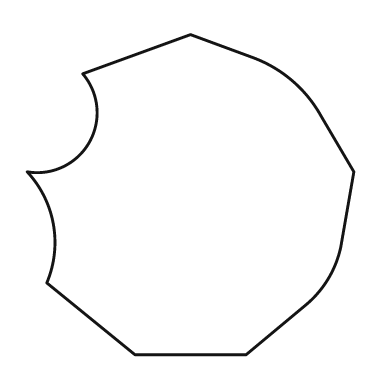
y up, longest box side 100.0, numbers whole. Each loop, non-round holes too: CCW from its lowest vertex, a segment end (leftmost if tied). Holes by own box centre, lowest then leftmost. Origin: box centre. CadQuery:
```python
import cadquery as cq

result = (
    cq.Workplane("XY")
    .moveTo(-17.0, -49.0)
    .lineTo(17.0, -49.0)
    .lineTo(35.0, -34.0)
    .threePointArc((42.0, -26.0), (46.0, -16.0))
    .lineTo(50.0, 7.0)
    .lineTo(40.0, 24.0)
    .threePointArc((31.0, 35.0), (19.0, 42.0))
    .lineTo(0.0, 49.0)
    .lineTo(-33.0, 37.0)
    .threePointArc((-31.0, 16.0), (-50.0, 7.0))
    .threePointArc((-42.0, -9.0), (-44.0, -27.0))
    .close()
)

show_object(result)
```